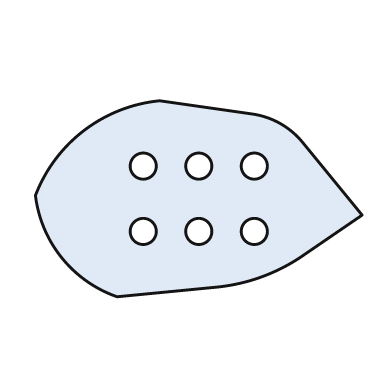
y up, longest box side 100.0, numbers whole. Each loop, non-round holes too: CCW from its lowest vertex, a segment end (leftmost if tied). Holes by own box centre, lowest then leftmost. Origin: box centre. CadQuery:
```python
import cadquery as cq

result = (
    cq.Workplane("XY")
    .moveTo(-25.0, -30.0)
    .lineTo(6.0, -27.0)
    .threePointArc((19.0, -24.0), (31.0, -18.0))
    .lineTo(50.0, -5.0)
    .lineTo(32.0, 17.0)
    .threePointArc((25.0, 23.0), (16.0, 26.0))
    .lineTo(-12.0, 30.0)
    .threePointArc((-35.0, 21.0), (-50.0, 1.0))
    .threePointArc((-42.0, -18.0), (-25.0, -30.0))
    .close()
    .moveTo(-17.0, -10.0)
    .circle(4.0)
    .moveTo(0.0, -10.0)
    .circle(4.0)
    .moveTo(17.0, -10.0)
    .circle(4.0)
    .moveTo(-17.0, 10.0)
    .circle(4.0)
    .moveTo(0.0, 10.0)
    .circle(4.0)
    .moveTo(17.0, 10.0)
    .circle(4.0)
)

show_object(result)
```